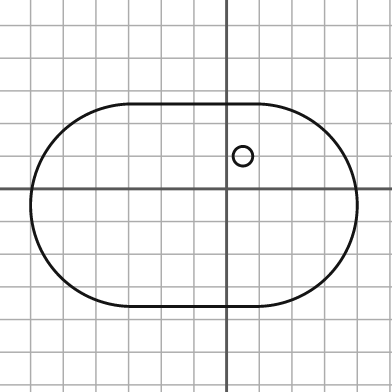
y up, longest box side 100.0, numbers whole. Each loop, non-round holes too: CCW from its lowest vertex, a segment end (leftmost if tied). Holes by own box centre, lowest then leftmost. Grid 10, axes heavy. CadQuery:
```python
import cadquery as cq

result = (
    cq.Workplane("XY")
    .moveTo(-29.0, -36.0)
    .lineTo(9.0, -36.0)
    .threePointArc((40.0, -5.0), (9.0, 26.0))
    .lineTo(-29.0, 26.0)
    .threePointArc((-60.0, -5.0), (-29.0, -36.0))
    .close()
    .moveTo(5.0, 10.0)
    .circle(3.0)
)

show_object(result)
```